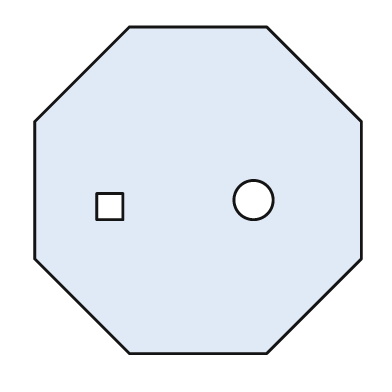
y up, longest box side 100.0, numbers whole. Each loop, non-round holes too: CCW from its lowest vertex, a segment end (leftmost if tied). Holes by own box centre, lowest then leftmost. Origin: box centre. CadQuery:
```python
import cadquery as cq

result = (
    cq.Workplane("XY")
    .moveTo(-21.0, -50.0)
    .lineTo(21.0, -50.0)
    .lineTo(50.0, -21.0)
    .lineTo(50.0, 21.0)
    .lineTo(21.0, 50.0)
    .lineTo(-21.0, 50.0)
    .lineTo(-50.0, 21.0)
    .lineTo(-50.0, -21.0)
    .close()
    .moveTo(-31.0, -9.0)
    .lineTo(-23.0, -9.0)
    .lineTo(-23.0, -1.0)
    .lineTo(-31.0, -1.0)
    .close()
    .moveTo(17.0, -3.0)
    .circle(6.0)
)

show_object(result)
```